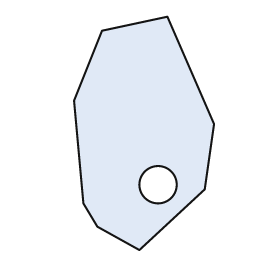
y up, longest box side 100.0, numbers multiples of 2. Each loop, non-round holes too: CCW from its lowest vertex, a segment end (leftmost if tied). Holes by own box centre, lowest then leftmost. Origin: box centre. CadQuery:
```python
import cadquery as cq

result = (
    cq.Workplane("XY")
    .moveTo(-2.0, -50.0)
    .lineTo(26.0, -24.0)
    .lineTo(30.0, 4.0)
    .lineTo(10.0, 50.0)
    .lineTo(-18.0, 44.0)
    .lineTo(-30.0, 14.0)
    .lineTo(-26.0, -30.0)
    .lineTo(-20.0, -40.0)
    .close()
    .moveTo(6.0, -22.0)
    .circle(8.0)
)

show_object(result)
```